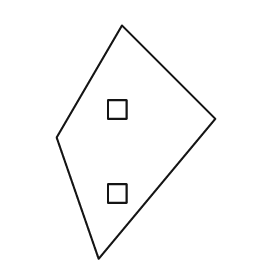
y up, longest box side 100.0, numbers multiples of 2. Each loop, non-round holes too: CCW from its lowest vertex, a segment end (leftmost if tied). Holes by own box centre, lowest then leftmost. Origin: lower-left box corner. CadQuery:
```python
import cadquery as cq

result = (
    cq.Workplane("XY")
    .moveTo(18.0, 0.0)
    .lineTo(68.0, 60.0)
    .lineTo(28.0, 100.0)
    .lineTo(0.0, 52.0)
    .close()
    .moveTo(22.0, 24.0)
    .lineTo(30.0, 24.0)
    .lineTo(30.0, 32.0)
    .lineTo(22.0, 32.0)
    .close()
    .moveTo(22.0, 60.0)
    .lineTo(30.0, 60.0)
    .lineTo(30.0, 68.0)
    .lineTo(22.0, 68.0)
    .close()
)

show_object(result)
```